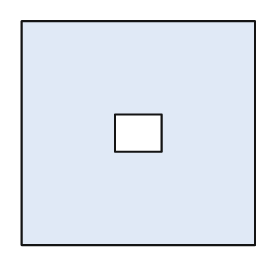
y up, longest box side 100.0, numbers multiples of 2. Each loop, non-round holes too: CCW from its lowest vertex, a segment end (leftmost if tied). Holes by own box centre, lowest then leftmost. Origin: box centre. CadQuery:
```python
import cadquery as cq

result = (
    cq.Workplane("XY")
    .moveTo(-50.0, -48.0)
    .lineTo(50.0, -48.0)
    .lineTo(50.0, 48.0)
    .lineTo(-50.0, 48.0)
    .close()
    .moveTo(-10.0, -8.0)
    .lineTo(10.0, -8.0)
    .lineTo(10.0, 8.0)
    .lineTo(-10.0, 8.0)
    .close()
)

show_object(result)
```